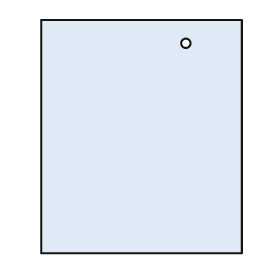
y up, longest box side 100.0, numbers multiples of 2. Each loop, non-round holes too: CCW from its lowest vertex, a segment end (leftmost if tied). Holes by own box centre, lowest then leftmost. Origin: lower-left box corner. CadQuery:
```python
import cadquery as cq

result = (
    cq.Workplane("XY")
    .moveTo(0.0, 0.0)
    .lineTo(86.0, 0.0)
    .lineTo(86.0, 100.0)
    .lineTo(0.0, 100.0)
    .close()
    .moveTo(62.0, 90.0)
    .circle(2.0)
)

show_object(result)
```